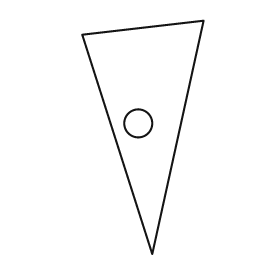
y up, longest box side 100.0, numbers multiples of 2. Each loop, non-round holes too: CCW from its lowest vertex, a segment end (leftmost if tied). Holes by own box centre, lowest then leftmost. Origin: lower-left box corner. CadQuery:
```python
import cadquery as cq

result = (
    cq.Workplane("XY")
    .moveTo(30.0, 0.0)
    .lineTo(52.0, 100.0)
    .lineTo(0.0, 94.0)
    .close()
    .moveTo(24.0, 56.0)
    .circle(6.0)
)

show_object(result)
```